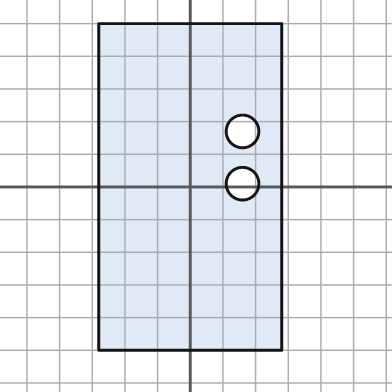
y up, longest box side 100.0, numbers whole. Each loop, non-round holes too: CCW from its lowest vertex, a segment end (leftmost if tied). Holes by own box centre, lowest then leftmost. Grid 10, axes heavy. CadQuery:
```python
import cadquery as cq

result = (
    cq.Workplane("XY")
    .moveTo(-28.0, -50.0)
    .lineTo(28.0, -50.0)
    .lineTo(28.0, 50.0)
    .lineTo(-28.0, 50.0)
    .close()
    .moveTo(16.0, 1.0)
    .circle(5.0)
    .moveTo(16.0, 17.0)
    .circle(5.0)
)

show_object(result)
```